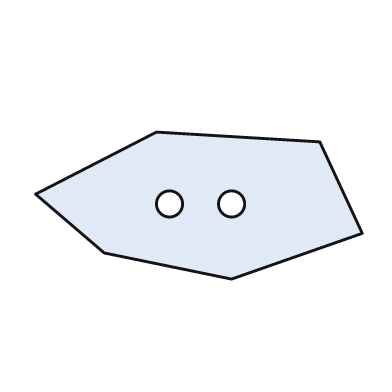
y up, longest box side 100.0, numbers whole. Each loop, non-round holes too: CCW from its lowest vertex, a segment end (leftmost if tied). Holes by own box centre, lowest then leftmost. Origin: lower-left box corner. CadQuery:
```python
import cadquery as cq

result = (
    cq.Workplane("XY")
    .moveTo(60.0, 0.0)
    .lineTo(100.0, 14.0)
    .lineTo(87.0, 42.0)
    .lineTo(37.0, 45.0)
    .lineTo(0.0, 26.0)
    .lineTo(21.0, 8.0)
    .close()
    .moveTo(41.0, 23.0)
    .circle(4.0)
    .moveTo(60.0, 23.0)
    .circle(4.0)
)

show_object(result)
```